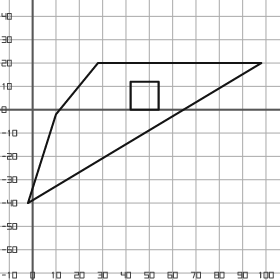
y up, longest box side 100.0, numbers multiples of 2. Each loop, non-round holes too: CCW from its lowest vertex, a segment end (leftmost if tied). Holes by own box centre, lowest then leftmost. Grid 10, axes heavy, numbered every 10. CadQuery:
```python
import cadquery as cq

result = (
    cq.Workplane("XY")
    .moveTo(-2.0, -40.0)
    .lineTo(98.0, 20.0)
    .lineTo(28.0, 20.0)
    .lineTo(10.0, -2.0)
    .close()
    .moveTo(42.0, 0.0)
    .lineTo(54.0, 0.0)
    .lineTo(54.0, 12.0)
    .lineTo(42.0, 12.0)
    .close()
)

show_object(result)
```